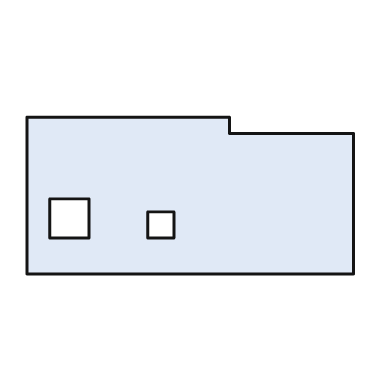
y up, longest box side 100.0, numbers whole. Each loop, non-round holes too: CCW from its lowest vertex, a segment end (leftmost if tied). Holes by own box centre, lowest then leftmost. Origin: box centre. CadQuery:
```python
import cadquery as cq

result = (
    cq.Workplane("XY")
    .moveTo(-50.0, -24.0)
    .lineTo(50.0, -24.0)
    .lineTo(50.0, 19.0)
    .lineTo(12.0, 19.0)
    .lineTo(12.0, 24.0)
    .lineTo(-50.0, 24.0)
    .close()
    .moveTo(-13.0, -13.0)
    .lineTo(-5.0, -13.0)
    .lineTo(-5.0, -5.0)
    .lineTo(-13.0, -5.0)
    .close()
    .moveTo(-43.0, -13.0)
    .lineTo(-31.0, -13.0)
    .lineTo(-31.0, -1.0)
    .lineTo(-43.0, -1.0)
    .close()
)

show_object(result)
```